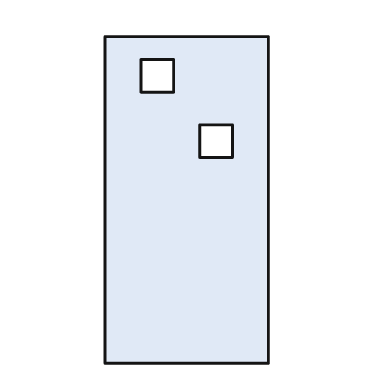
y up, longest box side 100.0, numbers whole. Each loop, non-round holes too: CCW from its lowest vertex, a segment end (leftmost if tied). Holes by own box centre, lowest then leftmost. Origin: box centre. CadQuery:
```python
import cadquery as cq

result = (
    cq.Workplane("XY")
    .moveTo(-25.0, -50.0)
    .lineTo(25.0, -50.0)
    .lineTo(25.0, 50.0)
    .lineTo(-25.0, 50.0)
    .close()
    .moveTo(4.0, 13.0)
    .lineTo(14.0, 13.0)
    .lineTo(14.0, 23.0)
    .lineTo(4.0, 23.0)
    .close()
    .moveTo(-14.0, 33.0)
    .lineTo(-4.0, 33.0)
    .lineTo(-4.0, 43.0)
    .lineTo(-14.0, 43.0)
    .close()
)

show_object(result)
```